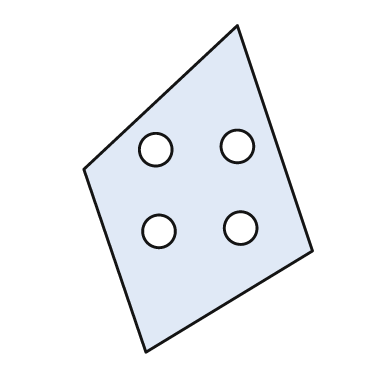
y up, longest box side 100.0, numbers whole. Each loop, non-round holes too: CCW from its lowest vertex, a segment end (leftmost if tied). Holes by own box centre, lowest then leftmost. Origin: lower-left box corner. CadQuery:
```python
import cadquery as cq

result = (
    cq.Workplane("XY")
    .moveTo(19.0, 0.0)
    .lineTo(70.0, 31.0)
    .lineTo(47.0, 100.0)
    .lineTo(0.0, 56.0)
    .close()
    .moveTo(23.0, 37.0)
    .circle(5.0)
    .moveTo(48.0, 38.0)
    .circle(5.0)
    .moveTo(22.0, 62.0)
    .circle(5.0)
    .moveTo(47.0, 63.0)
    .circle(5.0)
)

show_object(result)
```